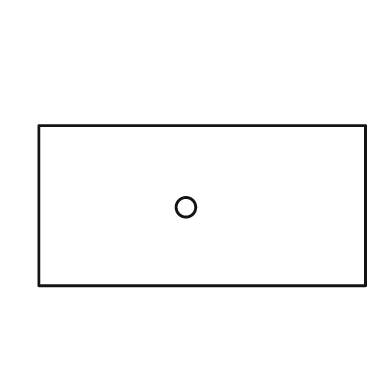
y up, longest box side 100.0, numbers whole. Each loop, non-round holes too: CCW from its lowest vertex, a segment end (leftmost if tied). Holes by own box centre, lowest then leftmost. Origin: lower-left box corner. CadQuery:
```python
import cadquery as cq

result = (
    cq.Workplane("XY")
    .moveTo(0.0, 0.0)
    .lineTo(100.0, 0.0)
    .lineTo(100.0, 49.0)
    .lineTo(0.0, 49.0)
    .close()
    .moveTo(45.0, 24.0)
    .circle(3.0)
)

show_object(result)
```